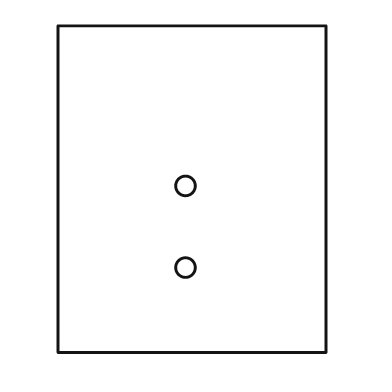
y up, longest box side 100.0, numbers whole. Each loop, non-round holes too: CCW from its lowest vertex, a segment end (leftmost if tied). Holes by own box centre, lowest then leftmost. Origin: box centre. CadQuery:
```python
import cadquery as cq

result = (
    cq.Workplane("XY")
    .moveTo(-41.0, -50.0)
    .lineTo(41.0, -50.0)
    .lineTo(41.0, 50.0)
    .lineTo(-41.0, 50.0)
    .close()
    .moveTo(-2.0, -24.0)
    .circle(3.0)
    .moveTo(-2.0, 1.0)
    .circle(3.0)
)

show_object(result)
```